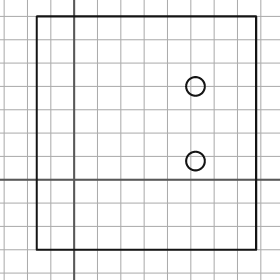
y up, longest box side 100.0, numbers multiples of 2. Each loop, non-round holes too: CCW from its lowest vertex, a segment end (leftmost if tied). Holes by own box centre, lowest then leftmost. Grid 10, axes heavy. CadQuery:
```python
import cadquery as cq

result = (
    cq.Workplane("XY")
    .moveTo(-16.0, -30.0)
    .lineTo(78.0, -30.0)
    .lineTo(78.0, 70.0)
    .lineTo(-16.0, 70.0)
    .close()
    .moveTo(52.0, 8.0)
    .circle(4.0)
    .moveTo(52.0, 40.0)
    .circle(4.0)
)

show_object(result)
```